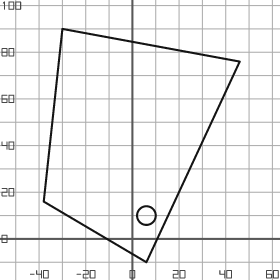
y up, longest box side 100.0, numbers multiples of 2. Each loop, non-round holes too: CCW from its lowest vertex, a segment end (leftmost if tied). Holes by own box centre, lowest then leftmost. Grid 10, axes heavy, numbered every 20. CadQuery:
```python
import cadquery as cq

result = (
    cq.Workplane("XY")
    .moveTo(6.0, -10.0)
    .lineTo(46.0, 76.0)
    .lineTo(-30.0, 90.0)
    .lineTo(-38.0, 16.0)
    .close()
    .moveTo(6.0, 10.0)
    .circle(4.0)
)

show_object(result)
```